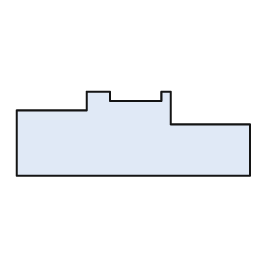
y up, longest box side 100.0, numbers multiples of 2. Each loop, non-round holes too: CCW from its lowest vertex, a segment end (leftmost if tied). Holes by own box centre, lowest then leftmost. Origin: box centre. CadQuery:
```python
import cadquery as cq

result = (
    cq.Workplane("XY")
    .moveTo(-50.0, -18.0)
    .lineTo(50.0, -18.0)
    .lineTo(50.0, 4.0)
    .lineTo(16.0, 4.0)
    .lineTo(16.0, 18.0)
    .lineTo(12.0, 18.0)
    .lineTo(12.0, 14.0)
    .lineTo(-10.0, 14.0)
    .lineTo(-10.0, 18.0)
    .lineTo(-20.0, 18.0)
    .lineTo(-20.0, 10.0)
    .lineTo(-50.0, 10.0)
    .close()
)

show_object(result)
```